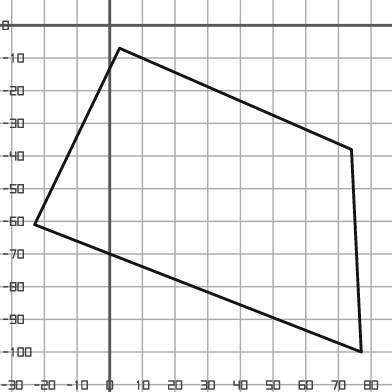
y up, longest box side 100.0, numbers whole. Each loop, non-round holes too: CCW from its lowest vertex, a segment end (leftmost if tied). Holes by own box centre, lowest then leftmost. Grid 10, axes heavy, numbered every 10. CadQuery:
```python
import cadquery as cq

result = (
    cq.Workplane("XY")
    .moveTo(77.0, -100.0)
    .lineTo(74.0, -38.0)
    .lineTo(3.0, -7.0)
    .lineTo(-23.0, -61.0)
    .close()
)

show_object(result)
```